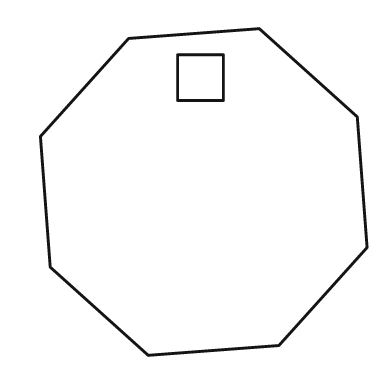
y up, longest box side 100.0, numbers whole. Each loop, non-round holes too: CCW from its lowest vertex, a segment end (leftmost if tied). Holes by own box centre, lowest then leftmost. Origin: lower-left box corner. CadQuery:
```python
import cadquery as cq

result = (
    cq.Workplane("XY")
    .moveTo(33.0, 0.0)
    .lineTo(73.0, 3.0)
    .lineTo(100.0, 33.0)
    .lineTo(97.0, 73.0)
    .lineTo(67.0, 100.0)
    .lineTo(27.0, 97.0)
    .lineTo(0.0, 67.0)
    .lineTo(3.0, 27.0)
    .close()
    .moveTo(42.0, 78.0)
    .lineTo(56.0, 78.0)
    .lineTo(56.0, 92.0)
    .lineTo(42.0, 92.0)
    .close()
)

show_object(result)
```